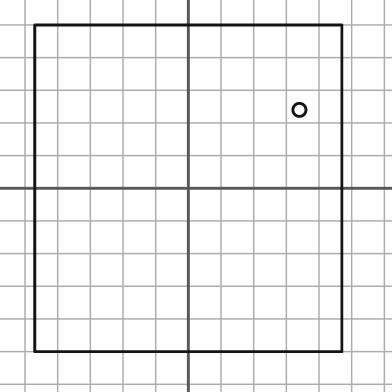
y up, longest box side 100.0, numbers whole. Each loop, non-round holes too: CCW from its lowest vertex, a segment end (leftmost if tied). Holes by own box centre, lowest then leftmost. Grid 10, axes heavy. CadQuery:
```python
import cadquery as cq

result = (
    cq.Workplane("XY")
    .moveTo(-47.0, -50.0)
    .lineTo(47.0, -50.0)
    .lineTo(47.0, 50.0)
    .lineTo(-47.0, 50.0)
    .close()
    .moveTo(34.0, 24.0)
    .circle(2.0)
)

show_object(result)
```